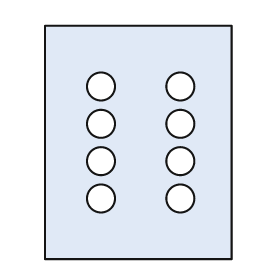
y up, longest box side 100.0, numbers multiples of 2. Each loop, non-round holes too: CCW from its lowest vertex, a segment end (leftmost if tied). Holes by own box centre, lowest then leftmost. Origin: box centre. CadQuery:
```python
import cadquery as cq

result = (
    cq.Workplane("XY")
    .moveTo(-40.0, -50.0)
    .lineTo(40.0, -50.0)
    .lineTo(40.0, 50.0)
    .lineTo(-40.0, 50.0)
    .close()
    .moveTo(-16.0, -24.0)
    .circle(6.0)
    .moveTo(18.0, -24.0)
    .circle(6.0)
    .moveTo(-16.0, -8.0)
    .circle(6.0)
    .moveTo(18.0, -8.0)
    .circle(6.0)
    .moveTo(-16.0, 8.0)
    .circle(6.0)
    .moveTo(18.0, 8.0)
    .circle(6.0)
    .moveTo(-16.0, 24.0)
    .circle(6.0)
    .moveTo(18.0, 24.0)
    .circle(6.0)
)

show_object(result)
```